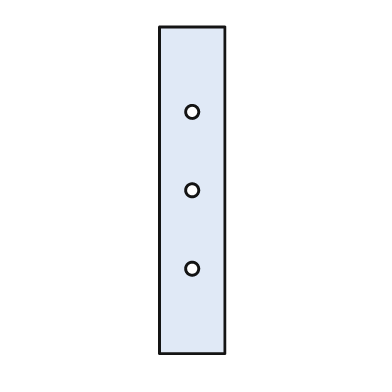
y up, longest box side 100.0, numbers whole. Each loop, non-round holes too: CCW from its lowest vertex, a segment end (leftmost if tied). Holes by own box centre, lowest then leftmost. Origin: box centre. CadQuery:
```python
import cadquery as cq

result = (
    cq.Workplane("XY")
    .moveTo(-10.0, -50.0)
    .lineTo(10.0, -50.0)
    .lineTo(10.0, 50.0)
    .lineTo(-10.0, 50.0)
    .close()
    .moveTo(0.0, -24.0)
    .circle(2.0)
    .moveTo(0.0, 0.0)
    .circle(2.0)
    .moveTo(0.0, 24.0)
    .circle(2.0)
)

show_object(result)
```